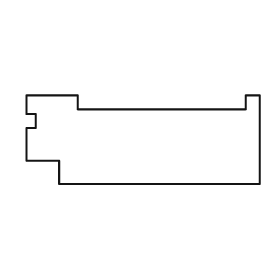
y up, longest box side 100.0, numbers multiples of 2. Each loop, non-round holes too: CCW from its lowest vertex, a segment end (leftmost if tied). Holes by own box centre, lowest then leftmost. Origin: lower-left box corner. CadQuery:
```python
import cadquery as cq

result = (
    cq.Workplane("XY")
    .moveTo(14.0, 0.0)
    .lineTo(100.0, 0.0)
    .lineTo(100.0, 38.0)
    .lineTo(94.0, 38.0)
    .lineTo(94.0, 32.0)
    .lineTo(22.0, 32.0)
    .lineTo(22.0, 38.0)
    .lineTo(0.0, 38.0)
    .lineTo(0.0, 30.0)
    .lineTo(4.0, 30.0)
    .lineTo(4.0, 24.0)
    .lineTo(0.0, 24.0)
    .lineTo(0.0, 10.0)
    .lineTo(14.0, 10.0)
    .close()
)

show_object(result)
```